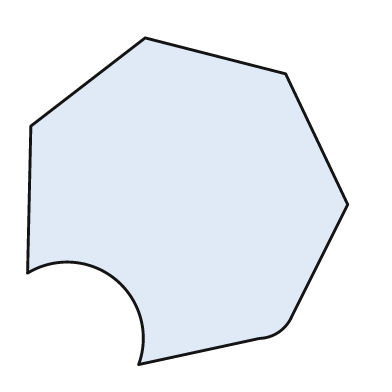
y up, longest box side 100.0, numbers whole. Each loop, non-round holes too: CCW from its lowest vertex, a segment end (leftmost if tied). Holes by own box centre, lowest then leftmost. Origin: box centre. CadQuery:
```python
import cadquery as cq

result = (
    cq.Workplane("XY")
    .moveTo(-15.0, -50.0)
    .lineTo(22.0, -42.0)
    .threePointArc((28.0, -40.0), (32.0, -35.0))
    .lineTo(49.0, -1.0)
    .lineTo(30.0, 39.0)
    .lineTo(-13.0, 50.0)
    .lineTo(-48.0, 23.0)
    .lineTo(-49.0, -22.0)
    .threePointArc((-22.0, -24.0), (-15.0, -50.0))
    .close()
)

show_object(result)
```